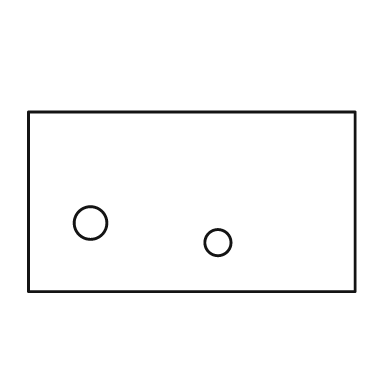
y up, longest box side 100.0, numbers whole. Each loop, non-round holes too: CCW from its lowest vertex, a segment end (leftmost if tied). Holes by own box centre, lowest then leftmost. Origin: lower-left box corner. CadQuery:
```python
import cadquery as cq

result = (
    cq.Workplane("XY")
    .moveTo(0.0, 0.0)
    .lineTo(100.0, 0.0)
    .lineTo(100.0, 55.0)
    .lineTo(0.0, 55.0)
    .close()
    .moveTo(58.0, 15.0)
    .circle(4.0)
    .moveTo(19.0, 21.0)
    .circle(5.0)
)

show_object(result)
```